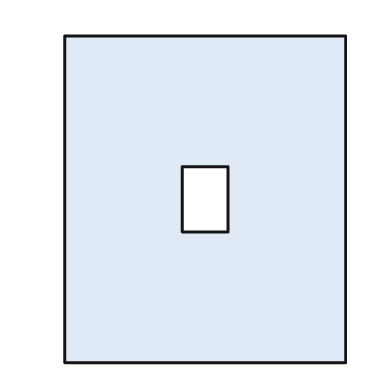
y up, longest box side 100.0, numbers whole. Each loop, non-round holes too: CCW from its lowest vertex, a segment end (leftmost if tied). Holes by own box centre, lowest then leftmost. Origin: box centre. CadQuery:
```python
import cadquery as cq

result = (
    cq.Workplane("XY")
    .moveTo(-43.0, -50.0)
    .lineTo(43.0, -50.0)
    .lineTo(43.0, 50.0)
    .lineTo(-43.0, 50.0)
    .close()
    .moveTo(-7.0, -10.0)
    .lineTo(7.0, -10.0)
    .lineTo(7.0, 10.0)
    .lineTo(-7.0, 10.0)
    .close()
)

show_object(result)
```